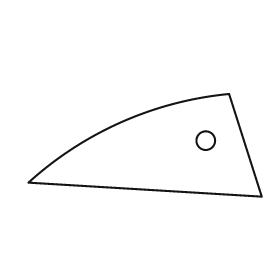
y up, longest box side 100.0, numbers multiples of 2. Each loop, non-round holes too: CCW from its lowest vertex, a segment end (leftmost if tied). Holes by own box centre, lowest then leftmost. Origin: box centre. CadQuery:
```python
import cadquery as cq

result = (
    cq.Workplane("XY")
    .moveTo(50.0, -22.0)
    .lineTo(36.0, 22.0)
    .threePointArc((-10.0, 10.0), (-50.0, -16.0))
    .close()
    .moveTo(26.0, 2.0)
    .circle(4.0)
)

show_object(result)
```